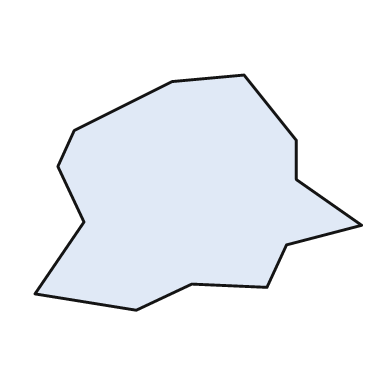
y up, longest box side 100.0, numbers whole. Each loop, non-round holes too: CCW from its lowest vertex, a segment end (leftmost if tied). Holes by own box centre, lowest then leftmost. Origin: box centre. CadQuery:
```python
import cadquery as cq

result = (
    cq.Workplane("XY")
    .moveTo(-19.0, -36.0)
    .lineTo(-2.0, -28.0)
    .lineTo(21.0, -29.0)
    .lineTo(27.0, -16.0)
    .lineTo(50.0, -10.0)
    .lineTo(30.0, 4.0)
    .lineTo(30.0, 16.0)
    .lineTo(14.0, 36.0)
    .lineTo(-8.0, 34.0)
    .lineTo(-38.0, 19.0)
    .lineTo(-43.0, 8.0)
    .lineTo(-35.0, -9.0)
    .lineTo(-50.0, -31.0)
    .close()
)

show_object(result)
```